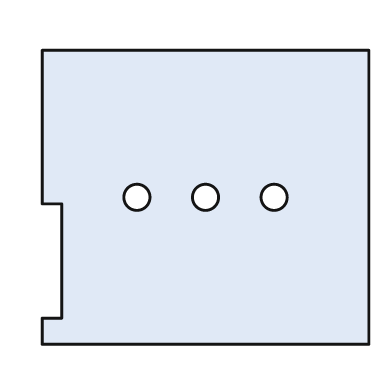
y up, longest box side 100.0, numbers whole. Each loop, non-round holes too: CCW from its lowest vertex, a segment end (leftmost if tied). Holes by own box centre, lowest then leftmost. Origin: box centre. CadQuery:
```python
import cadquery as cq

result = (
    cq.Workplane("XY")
    .moveTo(-50.0, -45.0)
    .lineTo(50.0, -45.0)
    .lineTo(50.0, 45.0)
    .lineTo(-50.0, 45.0)
    .lineTo(-50.0, -2.0)
    .lineTo(-44.0, -2.0)
    .lineTo(-44.0, -37.0)
    .lineTo(-50.0, -37.0)
    .close()
    .moveTo(-21.0, 0.0)
    .circle(4.0)
    .moveTo(0.0, 0.0)
    .circle(4.0)
    .moveTo(21.0, 0.0)
    .circle(4.0)
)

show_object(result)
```